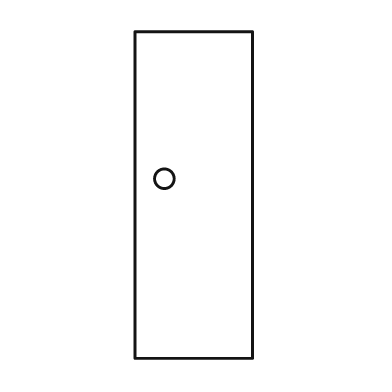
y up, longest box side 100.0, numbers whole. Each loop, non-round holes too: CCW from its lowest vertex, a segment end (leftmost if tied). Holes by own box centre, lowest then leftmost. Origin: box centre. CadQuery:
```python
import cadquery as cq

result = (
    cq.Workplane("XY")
    .moveTo(-18.0, -50.0)
    .lineTo(18.0, -50.0)
    .lineTo(18.0, 50.0)
    .lineTo(-18.0, 50.0)
    .close()
    .moveTo(-9.0, 5.0)
    .circle(3.0)
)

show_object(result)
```